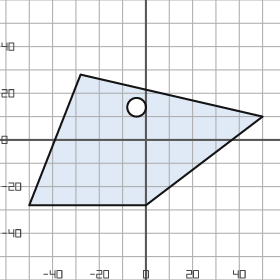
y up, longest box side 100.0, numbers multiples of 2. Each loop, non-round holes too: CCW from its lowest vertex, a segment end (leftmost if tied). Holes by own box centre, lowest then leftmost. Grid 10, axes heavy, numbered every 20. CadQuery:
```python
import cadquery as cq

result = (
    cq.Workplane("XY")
    .moveTo(-50.0, -28.0)
    .lineTo(0.0, -28.0)
    .lineTo(50.0, 10.0)
    .lineTo(-28.0, 28.0)
    .close()
    .moveTo(-4.0, 14.0)
    .circle(4.0)
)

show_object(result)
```